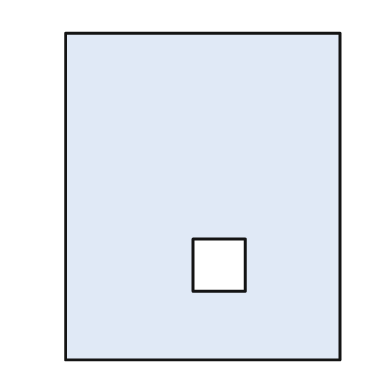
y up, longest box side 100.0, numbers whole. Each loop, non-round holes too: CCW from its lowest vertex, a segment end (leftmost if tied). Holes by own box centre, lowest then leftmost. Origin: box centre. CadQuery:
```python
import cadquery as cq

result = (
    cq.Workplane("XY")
    .moveTo(-42.0, -50.0)
    .lineTo(42.0, -50.0)
    .lineTo(42.0, 50.0)
    .lineTo(-42.0, 50.0)
    .close()
    .moveTo(-3.0, -29.0)
    .lineTo(13.0, -29.0)
    .lineTo(13.0, -13.0)
    .lineTo(-3.0, -13.0)
    .close()
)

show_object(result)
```